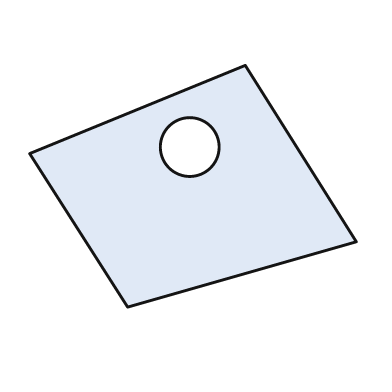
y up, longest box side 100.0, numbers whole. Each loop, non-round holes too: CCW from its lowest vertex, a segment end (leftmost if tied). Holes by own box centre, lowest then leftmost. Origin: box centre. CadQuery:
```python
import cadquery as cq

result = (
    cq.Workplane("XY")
    .moveTo(-20.0, -37.0)
    .lineTo(50.0, -17.0)
    .lineTo(16.0, 37.0)
    .lineTo(-50.0, 10.0)
    .close()
    .moveTo(-1.0, 12.0)
    .circle(9.0)
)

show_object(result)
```